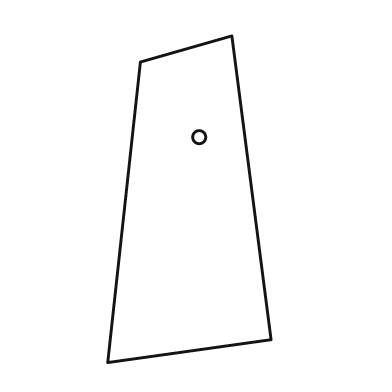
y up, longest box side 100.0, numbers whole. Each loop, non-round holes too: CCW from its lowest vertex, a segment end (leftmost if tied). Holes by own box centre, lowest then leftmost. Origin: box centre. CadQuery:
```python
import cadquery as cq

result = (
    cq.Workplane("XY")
    .moveTo(-25.0, -50.0)
    .lineTo(25.0, -43.0)
    .lineTo(13.0, 50.0)
    .lineTo(-15.0, 42.0)
    .close()
    .moveTo(3.0, 19.0)
    .circle(2.0)
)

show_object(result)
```